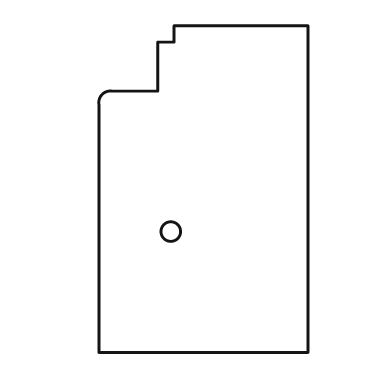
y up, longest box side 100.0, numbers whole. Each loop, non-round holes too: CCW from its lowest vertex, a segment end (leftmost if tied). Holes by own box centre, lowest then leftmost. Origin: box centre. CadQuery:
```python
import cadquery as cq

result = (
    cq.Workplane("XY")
    .moveTo(-32.0, -50.0)
    .lineTo(32.0, -50.0)
    .lineTo(32.0, 50.0)
    .lineTo(-9.0, 50.0)
    .lineTo(-9.0, 45.0)
    .lineTo(-14.0, 45.0)
    .lineTo(-14.0, 30.0)
    .lineTo(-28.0, 30.0)
    .threePointArc((-31.0, 29.0), (-32.0, 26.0))
    .close()
    .moveTo(-10.0, -13.0)
    .circle(3.0)
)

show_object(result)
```